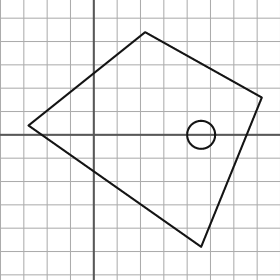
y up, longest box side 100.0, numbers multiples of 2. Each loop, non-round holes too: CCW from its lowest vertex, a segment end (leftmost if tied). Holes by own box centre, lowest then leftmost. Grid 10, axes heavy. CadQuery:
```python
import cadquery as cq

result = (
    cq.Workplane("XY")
    .moveTo(46.0, -48.0)
    .lineTo(72.0, 16.0)
    .lineTo(22.0, 44.0)
    .lineTo(-28.0, 4.0)
    .close()
    .moveTo(46.0, 0.0)
    .circle(6.0)
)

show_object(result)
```